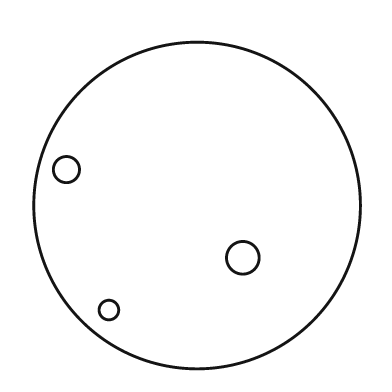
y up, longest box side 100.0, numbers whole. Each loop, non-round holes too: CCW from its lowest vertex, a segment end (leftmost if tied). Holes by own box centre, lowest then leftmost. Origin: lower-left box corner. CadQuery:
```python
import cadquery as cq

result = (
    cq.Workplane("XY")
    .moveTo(50.0, 50.0)
    .circle(50.0)
    .moveTo(23.0, 18.0)
    .circle(3.0)
    .moveTo(64.0, 34.0)
    .circle(5.0)
    .moveTo(10.0, 61.0)
    .circle(4.0)
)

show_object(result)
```